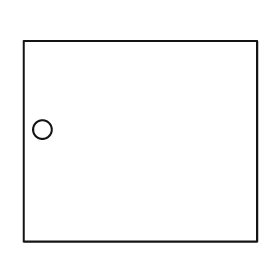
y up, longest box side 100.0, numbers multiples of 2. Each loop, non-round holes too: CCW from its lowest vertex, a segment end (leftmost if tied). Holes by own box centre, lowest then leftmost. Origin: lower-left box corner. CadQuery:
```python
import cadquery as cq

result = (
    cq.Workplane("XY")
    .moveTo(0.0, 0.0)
    .lineTo(100.0, 0.0)
    .lineTo(100.0, 86.0)
    .lineTo(0.0, 86.0)
    .close()
    .moveTo(8.0, 48.0)
    .circle(4.0)
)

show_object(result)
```